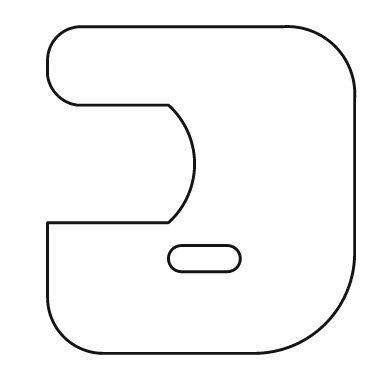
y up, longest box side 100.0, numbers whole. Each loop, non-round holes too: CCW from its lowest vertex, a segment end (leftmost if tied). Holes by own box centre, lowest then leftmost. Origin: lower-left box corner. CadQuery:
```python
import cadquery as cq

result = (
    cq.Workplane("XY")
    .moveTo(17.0, 0.0)
    .lineTo(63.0, 0.0)
    .threePointArc((85.0, 9.0), (94.0, 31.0))
    .lineTo(94.0, 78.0)
    .threePointArc((88.0, 94.0), (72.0, 100.0))
    .lineTo(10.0, 100.0)
    .threePointArc((3.0, 97.0), (0.0, 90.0))
    .lineTo(0.0, 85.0)
    .threePointArc((3.0, 79.0), (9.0, 76.0))
    .lineTo(37.0, 76.0)
    .threePointArc((45.0, 58.0), (37.0, 40.0))
    .lineTo(0.0, 40.0)
    .lineTo(0.0, 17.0)
    .threePointArc((5.0, 5.0), (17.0, 0.0))
    .close()
    .moveTo(41.0, 25.0)
    .lineTo(55.0, 25.0)
    .threePointArc((59.0, 29.0), (55.0, 33.0))
    .lineTo(41.0, 33.0)
    .threePointArc((37.0, 29.0), (41.0, 25.0))
    .close()
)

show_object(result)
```